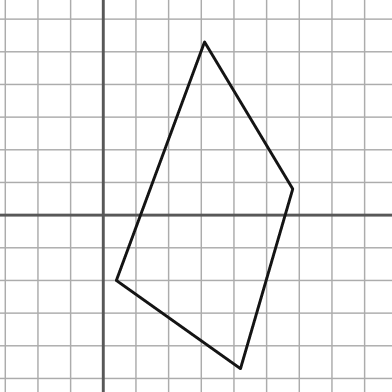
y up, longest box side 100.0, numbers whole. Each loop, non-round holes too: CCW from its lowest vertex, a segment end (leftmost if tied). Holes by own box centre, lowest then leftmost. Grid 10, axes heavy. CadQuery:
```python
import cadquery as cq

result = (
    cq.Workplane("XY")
    .moveTo(42.0, -47.0)
    .lineTo(58.0, 8.0)
    .lineTo(31.0, 53.0)
    .lineTo(4.0, -20.0)
    .close()
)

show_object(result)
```